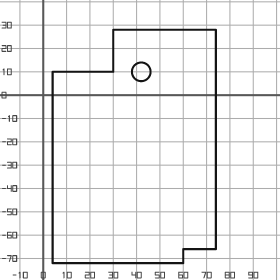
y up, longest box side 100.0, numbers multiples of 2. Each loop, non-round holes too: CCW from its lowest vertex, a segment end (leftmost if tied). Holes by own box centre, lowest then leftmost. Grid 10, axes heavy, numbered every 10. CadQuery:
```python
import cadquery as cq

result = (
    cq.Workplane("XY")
    .moveTo(4.0, -72.0)
    .lineTo(60.0, -72.0)
    .lineTo(60.0, -66.0)
    .lineTo(74.0, -66.0)
    .lineTo(74.0, 28.0)
    .lineTo(30.0, 28.0)
    .lineTo(30.0, 10.0)
    .lineTo(4.0, 10.0)
    .close()
    .moveTo(42.0, 10.0)
    .circle(4.0)
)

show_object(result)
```